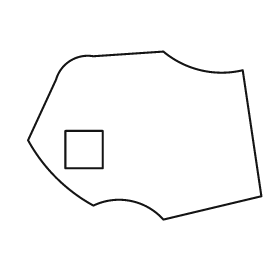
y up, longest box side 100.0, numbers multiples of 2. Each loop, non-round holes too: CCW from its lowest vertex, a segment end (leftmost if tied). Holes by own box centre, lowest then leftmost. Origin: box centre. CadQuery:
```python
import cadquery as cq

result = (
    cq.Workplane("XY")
    .moveTo(8.0, -36.0)
    .lineTo(50.0, -26.0)
    .lineTo(42.0, 28.0)
    .threePointArc((24.0, 28.0), (8.0, 36.0))
    .lineTo(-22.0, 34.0)
    .threePointArc((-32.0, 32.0), (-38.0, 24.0))
    .lineTo(-50.0, -2.0)
    .threePointArc((-38.0, -18.0), (-22.0, -30.0))
    .threePointArc((-6.0, -28.0), (8.0, -36.0))
    .close()
    .moveTo(-34.0, -14.0)
    .lineTo(-18.0, -14.0)
    .lineTo(-18.0, 2.0)
    .lineTo(-34.0, 2.0)
    .close()
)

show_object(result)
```